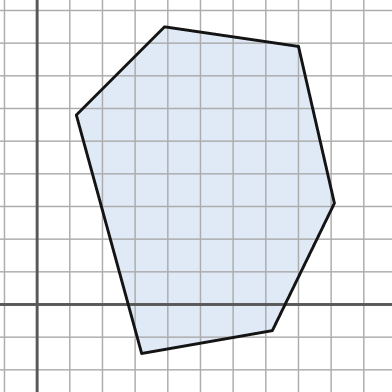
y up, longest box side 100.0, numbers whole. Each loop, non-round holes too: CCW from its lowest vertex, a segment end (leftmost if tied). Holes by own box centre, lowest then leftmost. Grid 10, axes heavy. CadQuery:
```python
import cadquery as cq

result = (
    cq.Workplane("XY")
    .moveTo(32.0, -15.0)
    .lineTo(72.0, -8.0)
    .lineTo(91.0, 31.0)
    .lineTo(80.0, 79.0)
    .lineTo(39.0, 85.0)
    .lineTo(12.0, 58.0)
    .close()
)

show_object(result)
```